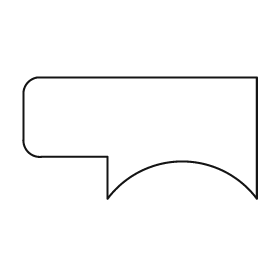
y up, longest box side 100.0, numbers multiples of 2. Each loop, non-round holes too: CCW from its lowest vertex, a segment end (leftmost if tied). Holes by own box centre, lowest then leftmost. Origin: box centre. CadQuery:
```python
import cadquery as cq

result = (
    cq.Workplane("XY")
    .moveTo(-14.0, -26.0)
    .threePointArc((18.0, -10.0), (50.0, -26.0))
    .lineTo(50.0, 26.0)
    .lineTo(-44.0, 26.0)
    .threePointArc((-48.0, 24.0), (-50.0, 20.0))
    .lineTo(-50.0, 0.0)
    .threePointArc((-48.0, -6.0), (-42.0, -8.0))
    .lineTo(-14.0, -8.0)
    .close()
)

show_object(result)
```